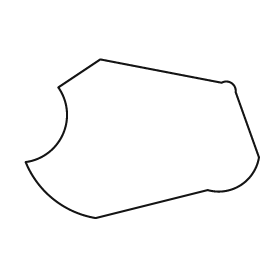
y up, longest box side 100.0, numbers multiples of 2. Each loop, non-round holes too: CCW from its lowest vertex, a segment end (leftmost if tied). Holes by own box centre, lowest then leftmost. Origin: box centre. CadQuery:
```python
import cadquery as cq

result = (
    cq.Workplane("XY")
    .moveTo(-20.0, -34.0)
    .lineTo(28.0, -22.0)
    .threePointArc((42.0, -20.0), (50.0, -8.0))
    .lineTo(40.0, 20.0)
    .threePointArc((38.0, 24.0), (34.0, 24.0))
    .lineTo(-18.0, 34.0)
    .lineTo(-36.0, 22.0)
    .threePointArc((-34.0, 2.0), (-50.0, -10.0))
    .threePointArc((-38.0, -26.0), (-20.0, -34.0))
    .close()
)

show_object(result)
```